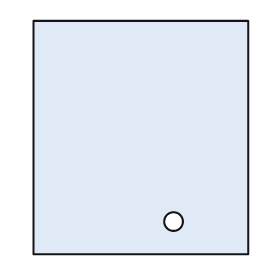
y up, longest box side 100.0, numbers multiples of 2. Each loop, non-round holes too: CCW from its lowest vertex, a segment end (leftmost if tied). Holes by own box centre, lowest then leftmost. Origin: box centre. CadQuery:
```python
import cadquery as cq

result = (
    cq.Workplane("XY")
    .moveTo(-46.0, -50.0)
    .lineTo(46.0, -50.0)
    .lineTo(46.0, 50.0)
    .lineTo(-46.0, 50.0)
    .close()
    .moveTo(14.0, -36.0)
    .circle(4.0)
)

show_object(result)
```